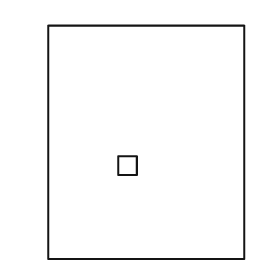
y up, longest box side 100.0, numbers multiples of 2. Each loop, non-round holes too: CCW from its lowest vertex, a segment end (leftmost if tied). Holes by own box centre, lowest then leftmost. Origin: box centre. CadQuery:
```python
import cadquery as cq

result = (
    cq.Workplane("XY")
    .moveTo(-42.0, -50.0)
    .lineTo(42.0, -50.0)
    .lineTo(42.0, 50.0)
    .lineTo(-42.0, 50.0)
    .close()
    .moveTo(-12.0, -14.0)
    .lineTo(-4.0, -14.0)
    .lineTo(-4.0, -6.0)
    .lineTo(-12.0, -6.0)
    .close()
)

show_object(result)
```